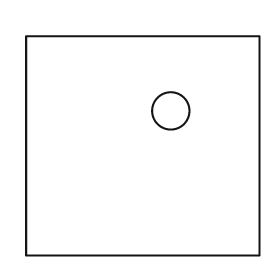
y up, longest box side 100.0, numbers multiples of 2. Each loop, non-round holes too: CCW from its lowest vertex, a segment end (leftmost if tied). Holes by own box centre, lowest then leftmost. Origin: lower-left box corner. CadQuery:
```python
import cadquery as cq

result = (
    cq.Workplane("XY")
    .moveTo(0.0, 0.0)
    .lineTo(100.0, 0.0)
    .lineTo(100.0, 94.0)
    .lineTo(0.0, 94.0)
    .close()
    .moveTo(62.0, 62.0)
    .circle(8.0)
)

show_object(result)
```